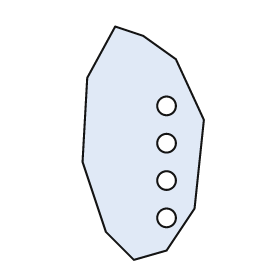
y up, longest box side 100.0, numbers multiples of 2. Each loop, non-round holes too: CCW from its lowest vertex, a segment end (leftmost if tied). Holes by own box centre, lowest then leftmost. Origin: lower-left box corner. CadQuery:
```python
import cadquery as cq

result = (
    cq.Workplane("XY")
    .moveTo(22.0, 0.0)
    .lineTo(36.0, 4.0)
    .lineTo(48.0, 22.0)
    .lineTo(52.0, 60.0)
    .lineTo(40.0, 86.0)
    .lineTo(26.0, 96.0)
    .lineTo(14.0, 100.0)
    .lineTo(2.0, 78.0)
    .lineTo(0.0, 42.0)
    .lineTo(10.0, 12.0)
    .close()
    .moveTo(36.0, 18.0)
    .circle(4.0)
    .moveTo(36.0, 34.0)
    .circle(4.0)
    .moveTo(36.0, 50.0)
    .circle(4.0)
    .moveTo(36.0, 66.0)
    .circle(4.0)
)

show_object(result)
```